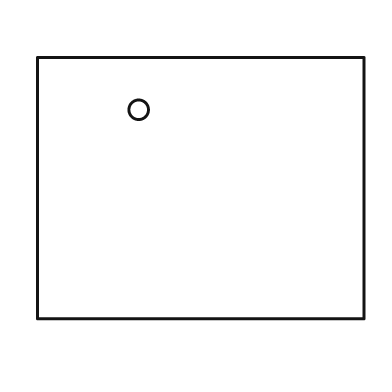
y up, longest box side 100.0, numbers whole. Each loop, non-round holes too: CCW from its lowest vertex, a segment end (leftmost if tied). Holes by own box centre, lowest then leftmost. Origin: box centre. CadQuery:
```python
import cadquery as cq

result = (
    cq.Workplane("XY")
    .moveTo(-50.0, -40.0)
    .lineTo(50.0, -40.0)
    .lineTo(50.0, 40.0)
    .lineTo(-50.0, 40.0)
    .close()
    .moveTo(-19.0, 24.0)
    .circle(3.0)
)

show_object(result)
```